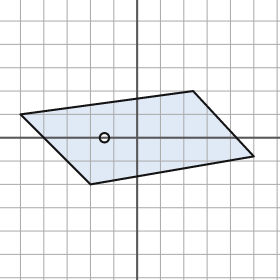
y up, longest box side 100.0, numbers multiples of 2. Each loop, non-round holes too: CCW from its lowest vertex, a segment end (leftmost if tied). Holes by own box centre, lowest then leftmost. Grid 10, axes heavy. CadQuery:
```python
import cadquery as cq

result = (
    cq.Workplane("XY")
    .moveTo(-20.0, -20.0)
    .lineTo(50.0, -8.0)
    .lineTo(24.0, 20.0)
    .lineTo(-50.0, 10.0)
    .close()
    .moveTo(-14.0, 0.0)
    .circle(2.0)
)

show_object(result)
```